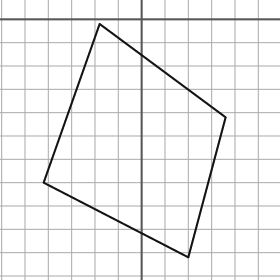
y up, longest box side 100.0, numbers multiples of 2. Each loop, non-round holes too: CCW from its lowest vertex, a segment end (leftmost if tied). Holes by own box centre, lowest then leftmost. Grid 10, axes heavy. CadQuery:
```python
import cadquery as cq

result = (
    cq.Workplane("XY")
    .moveTo(20.0, -102.0)
    .lineTo(36.0, -42.0)
    .lineTo(-18.0, -2.0)
    .lineTo(-42.0, -70.0)
    .close()
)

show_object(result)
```